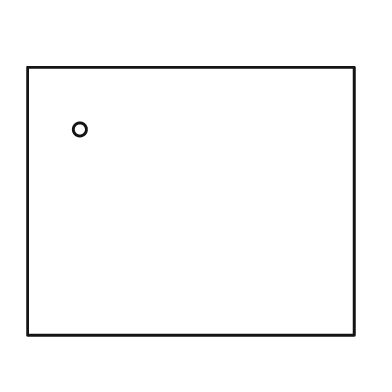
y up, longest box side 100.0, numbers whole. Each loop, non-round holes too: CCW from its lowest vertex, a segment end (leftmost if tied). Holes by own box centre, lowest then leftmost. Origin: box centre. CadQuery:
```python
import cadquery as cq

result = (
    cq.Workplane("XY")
    .moveTo(-50.0, -41.0)
    .lineTo(50.0, -41.0)
    .lineTo(50.0, 41.0)
    .lineTo(-50.0, 41.0)
    .close()
    .moveTo(-34.0, 22.0)
    .circle(2.0)
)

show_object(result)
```